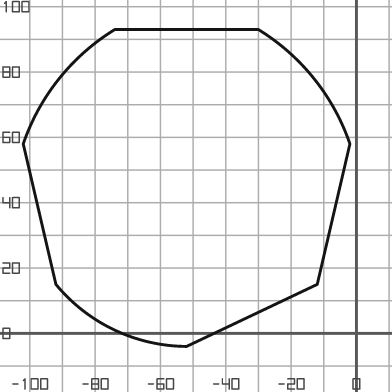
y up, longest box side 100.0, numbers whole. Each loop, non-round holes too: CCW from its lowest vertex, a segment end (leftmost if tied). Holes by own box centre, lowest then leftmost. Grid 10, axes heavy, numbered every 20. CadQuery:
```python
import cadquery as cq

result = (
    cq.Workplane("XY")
    .moveTo(-52.0, -4.0)
    .lineTo(-12.0, 15.0)
    .lineTo(-2.0, 58.0)
    .threePointArc((-13.0, 78.0), (-30.0, 93.0))
    .lineTo(-74.0, 93.0)
    .threePointArc((-91.0, 78.0), (-102.0, 58.0))
    .lineTo(-92.0, 15.0)
    .threePointArc((-74.0, 1.0), (-52.0, -4.0))
    .close()
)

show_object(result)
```